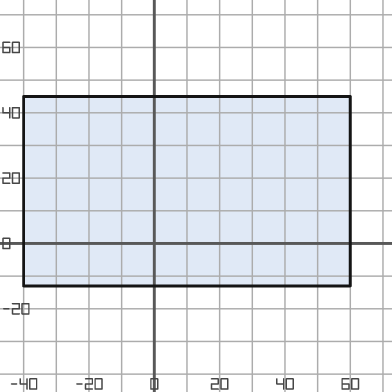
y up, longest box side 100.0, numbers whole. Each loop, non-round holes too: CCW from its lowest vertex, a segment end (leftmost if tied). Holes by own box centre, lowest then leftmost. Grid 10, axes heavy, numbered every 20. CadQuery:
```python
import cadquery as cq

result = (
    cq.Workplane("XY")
    .moveTo(-40.0, -13.0)
    .lineTo(60.0, -13.0)
    .lineTo(60.0, 45.0)
    .lineTo(-40.0, 45.0)
    .close()
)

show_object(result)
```